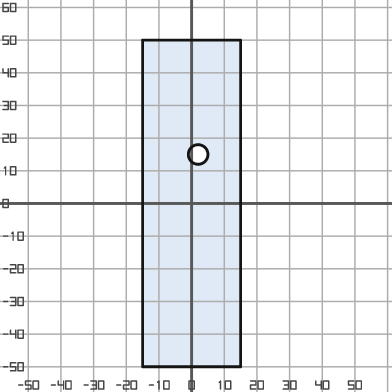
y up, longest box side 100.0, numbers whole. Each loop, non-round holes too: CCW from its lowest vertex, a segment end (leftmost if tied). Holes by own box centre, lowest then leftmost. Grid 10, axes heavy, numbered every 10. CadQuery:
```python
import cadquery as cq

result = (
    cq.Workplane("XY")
    .moveTo(-15.0, -50.0)
    .lineTo(15.0, -50.0)
    .lineTo(15.0, 50.0)
    .lineTo(-15.0, 50.0)
    .close()
    .moveTo(2.0, 15.0)
    .circle(3.0)
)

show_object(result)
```